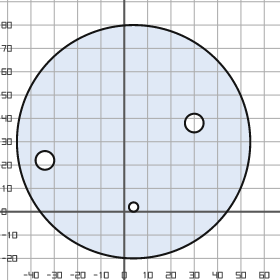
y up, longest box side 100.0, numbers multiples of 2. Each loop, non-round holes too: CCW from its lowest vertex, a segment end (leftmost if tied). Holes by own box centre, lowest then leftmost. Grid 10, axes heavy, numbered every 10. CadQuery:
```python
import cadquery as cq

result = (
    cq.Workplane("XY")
    .moveTo(4.0, 30.0)
    .circle(50.0)
    .moveTo(4.0, 2.0)
    .circle(2.0)
    .moveTo(-34.0, 22.0)
    .circle(4.0)
    .moveTo(30.0, 38.0)
    .circle(4.0)
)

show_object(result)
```